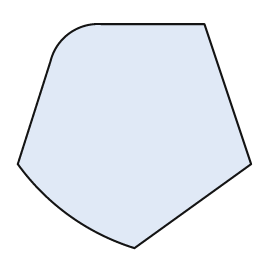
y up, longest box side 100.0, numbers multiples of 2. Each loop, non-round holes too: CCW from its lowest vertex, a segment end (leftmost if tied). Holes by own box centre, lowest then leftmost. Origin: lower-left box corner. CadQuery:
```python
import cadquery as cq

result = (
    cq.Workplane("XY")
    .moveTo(50.0, 0.0)
    .lineTo(100.0, 36.0)
    .lineTo(80.0, 96.0)
    .lineTo(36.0, 96.0)
    .threePointArc((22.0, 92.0), (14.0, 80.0))
    .lineTo(0.0, 36.0)
    .threePointArc((22.0, 14.0), (50.0, 0.0))
    .close()
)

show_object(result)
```